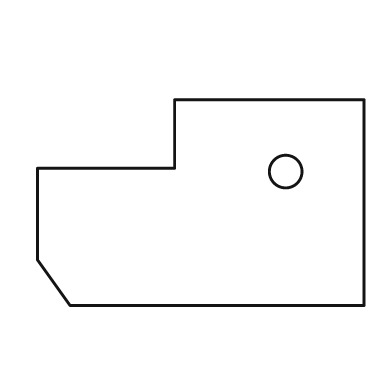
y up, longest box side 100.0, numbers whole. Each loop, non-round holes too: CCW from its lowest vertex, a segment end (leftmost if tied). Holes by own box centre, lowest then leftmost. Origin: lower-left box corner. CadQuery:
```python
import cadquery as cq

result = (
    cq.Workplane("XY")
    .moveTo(10.0, 0.0)
    .lineTo(100.0, 0.0)
    .lineTo(100.0, 63.0)
    .lineTo(42.0, 63.0)
    .lineTo(42.0, 42.0)
    .lineTo(0.0, 42.0)
    .lineTo(0.0, 14.0)
    .close()
    .moveTo(76.0, 41.0)
    .circle(5.0)
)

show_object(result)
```